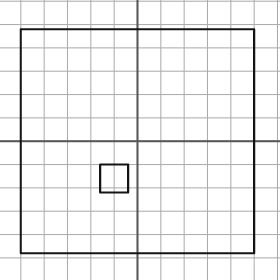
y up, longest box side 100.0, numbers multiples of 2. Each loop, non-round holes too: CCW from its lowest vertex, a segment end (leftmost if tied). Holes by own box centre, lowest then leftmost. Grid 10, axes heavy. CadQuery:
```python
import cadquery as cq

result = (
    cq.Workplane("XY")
    .moveTo(-50.0, -48.0)
    .lineTo(50.0, -48.0)
    .lineTo(50.0, 48.0)
    .lineTo(-50.0, 48.0)
    .close()
    .moveTo(-16.0, -22.0)
    .lineTo(-4.0, -22.0)
    .lineTo(-4.0, -10.0)
    .lineTo(-16.0, -10.0)
    .close()
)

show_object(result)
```